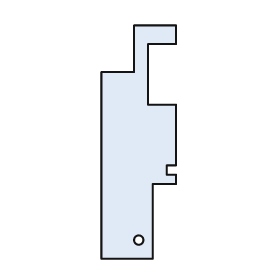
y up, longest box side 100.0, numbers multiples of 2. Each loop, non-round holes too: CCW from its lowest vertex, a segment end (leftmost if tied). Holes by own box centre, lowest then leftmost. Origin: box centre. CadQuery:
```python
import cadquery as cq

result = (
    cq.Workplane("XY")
    .moveTo(-16.0, -50.0)
    .lineTo(6.0, -50.0)
    .lineTo(6.0, -18.0)
    .lineTo(16.0, -18.0)
    .lineTo(16.0, -14.0)
    .lineTo(12.0, -14.0)
    .lineTo(12.0, -10.0)
    .lineTo(16.0, -10.0)
    .lineTo(16.0, 16.0)
    .lineTo(4.0, 16.0)
    .lineTo(4.0, 42.0)
    .lineTo(16.0, 42.0)
    .lineTo(16.0, 50.0)
    .lineTo(-2.0, 50.0)
    .lineTo(-2.0, 30.0)
    .lineTo(-16.0, 30.0)
    .close()
    .moveTo(0.0, -42.0)
    .circle(2.0)
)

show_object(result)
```